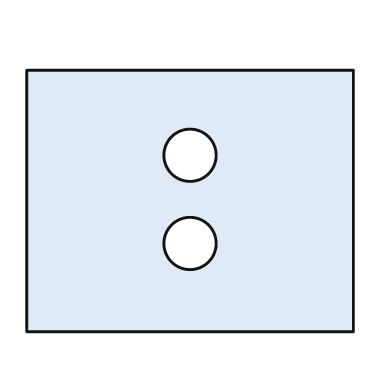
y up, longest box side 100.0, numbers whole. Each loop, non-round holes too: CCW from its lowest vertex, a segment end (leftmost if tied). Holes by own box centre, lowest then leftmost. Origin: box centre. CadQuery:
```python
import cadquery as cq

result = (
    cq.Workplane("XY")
    .moveTo(-50.0, -40.0)
    .lineTo(50.0, -40.0)
    .lineTo(50.0, 40.0)
    .lineTo(-50.0, 40.0)
    .close()
    .moveTo(0.0, -13.0)
    .circle(8.0)
    .moveTo(0.0, 14.0)
    .circle(8.0)
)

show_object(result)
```